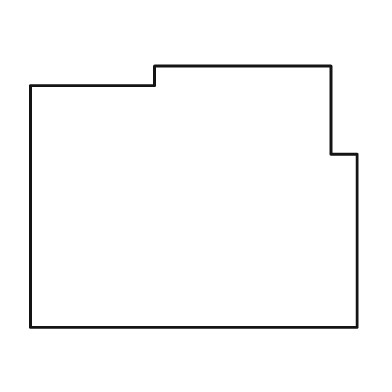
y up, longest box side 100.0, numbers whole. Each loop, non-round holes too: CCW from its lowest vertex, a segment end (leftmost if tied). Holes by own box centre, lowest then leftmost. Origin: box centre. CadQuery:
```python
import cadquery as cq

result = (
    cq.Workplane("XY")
    .moveTo(-50.0, -40.0)
    .lineTo(50.0, -40.0)
    .lineTo(50.0, 13.0)
    .lineTo(42.0, 13.0)
    .lineTo(42.0, 40.0)
    .lineTo(-12.0, 40.0)
    .lineTo(-12.0, 34.0)
    .lineTo(-50.0, 34.0)
    .close()
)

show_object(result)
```